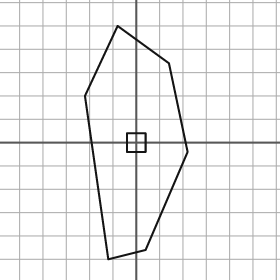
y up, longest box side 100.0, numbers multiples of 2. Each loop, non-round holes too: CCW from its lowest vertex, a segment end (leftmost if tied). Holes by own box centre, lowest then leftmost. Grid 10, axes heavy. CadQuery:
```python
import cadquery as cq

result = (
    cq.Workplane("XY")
    .moveTo(-12.0, -50.0)
    .lineTo(4.0, -46.0)
    .lineTo(22.0, -4.0)
    .lineTo(14.0, 34.0)
    .lineTo(-8.0, 50.0)
    .lineTo(-22.0, 20.0)
    .close()
    .moveTo(-4.0, -4.0)
    .lineTo(4.0, -4.0)
    .lineTo(4.0, 4.0)
    .lineTo(-4.0, 4.0)
    .close()
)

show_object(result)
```